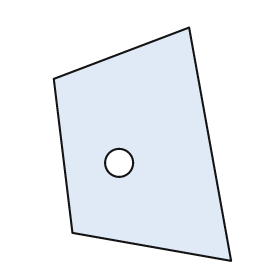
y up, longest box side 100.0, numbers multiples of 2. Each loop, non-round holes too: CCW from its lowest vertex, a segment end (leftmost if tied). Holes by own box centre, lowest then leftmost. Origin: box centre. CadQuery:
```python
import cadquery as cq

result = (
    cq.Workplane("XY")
    .moveTo(38.0, -50.0)
    .lineTo(20.0, 50.0)
    .lineTo(-38.0, 28.0)
    .lineTo(-30.0, -38.0)
    .close()
    .moveTo(-10.0, -8.0)
    .circle(6.0)
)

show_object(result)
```